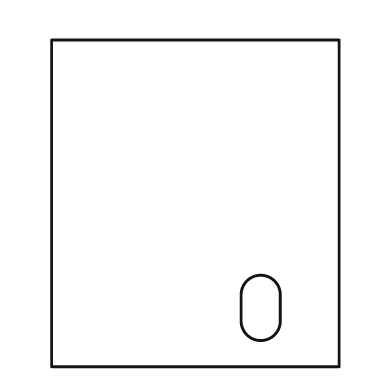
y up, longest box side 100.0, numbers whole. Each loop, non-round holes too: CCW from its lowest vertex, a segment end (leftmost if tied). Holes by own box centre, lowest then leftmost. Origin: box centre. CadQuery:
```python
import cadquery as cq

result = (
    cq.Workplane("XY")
    .moveTo(-44.0, -50.0)
    .lineTo(44.0, -50.0)
    .lineTo(44.0, 50.0)
    .lineTo(-44.0, 50.0)
    .close()
    .moveTo(14.0, -36.0)
    .threePointArc((20.0, -42.0), (26.0, -36.0))
    .lineTo(26.0, -28.0)
    .threePointArc((20.0, -22.0), (14.0, -28.0))
    .close()
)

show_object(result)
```